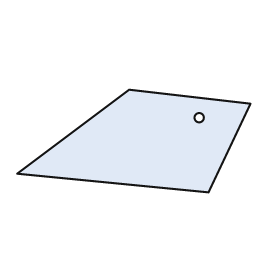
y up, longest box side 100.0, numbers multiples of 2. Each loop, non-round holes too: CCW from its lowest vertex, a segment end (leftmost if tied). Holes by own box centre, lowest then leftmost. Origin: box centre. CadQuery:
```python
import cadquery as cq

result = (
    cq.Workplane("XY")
    .moveTo(32.0, -22.0)
    .lineTo(50.0, 16.0)
    .lineTo(-2.0, 22.0)
    .lineTo(-50.0, -14.0)
    .close()
    .moveTo(28.0, 10.0)
    .circle(2.0)
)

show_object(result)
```